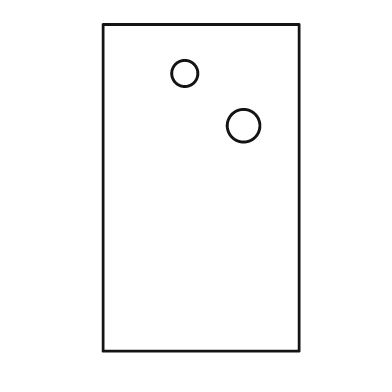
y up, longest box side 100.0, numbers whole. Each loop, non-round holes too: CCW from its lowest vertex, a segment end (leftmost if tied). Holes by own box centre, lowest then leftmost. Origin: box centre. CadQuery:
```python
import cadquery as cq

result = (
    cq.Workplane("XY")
    .moveTo(-30.0, -50.0)
    .lineTo(30.0, -50.0)
    .lineTo(30.0, 50.0)
    .lineTo(-30.0, 50.0)
    .close()
    .moveTo(13.0, 19.0)
    .circle(5.0)
    .moveTo(-5.0, 35.0)
    .circle(4.0)
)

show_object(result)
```